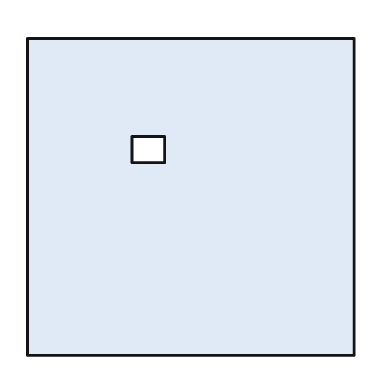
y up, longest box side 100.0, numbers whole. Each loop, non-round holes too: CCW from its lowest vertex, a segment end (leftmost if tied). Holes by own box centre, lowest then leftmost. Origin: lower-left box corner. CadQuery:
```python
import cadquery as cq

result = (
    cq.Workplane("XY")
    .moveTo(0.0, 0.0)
    .lineTo(100.0, 0.0)
    .lineTo(100.0, 97.0)
    .lineTo(0.0, 97.0)
    .close()
    .moveTo(32.0, 59.0)
    .lineTo(42.0, 59.0)
    .lineTo(42.0, 67.0)
    .lineTo(32.0, 67.0)
    .close()
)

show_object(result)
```